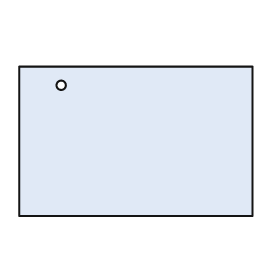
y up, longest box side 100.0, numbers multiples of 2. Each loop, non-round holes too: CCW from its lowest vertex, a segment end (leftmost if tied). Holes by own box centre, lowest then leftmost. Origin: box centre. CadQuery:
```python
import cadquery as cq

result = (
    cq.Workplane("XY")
    .moveTo(-50.0, -32.0)
    .lineTo(50.0, -32.0)
    .lineTo(50.0, 32.0)
    .lineTo(-50.0, 32.0)
    .close()
    .moveTo(-32.0, 24.0)
    .circle(2.0)
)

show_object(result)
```